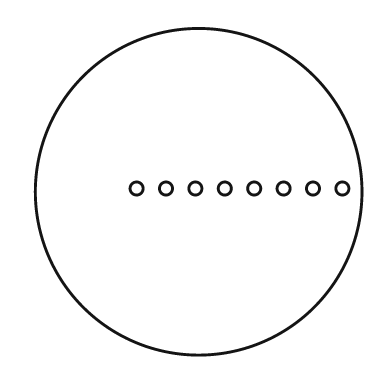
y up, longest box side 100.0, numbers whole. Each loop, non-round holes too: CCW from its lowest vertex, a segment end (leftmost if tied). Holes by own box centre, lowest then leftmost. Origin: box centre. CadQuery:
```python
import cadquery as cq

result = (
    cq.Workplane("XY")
    .moveTo(0.0, 0.0)
    .circle(50.0)
    .moveTo(-19.0, 1.0)
    .circle(2.0)
    .moveTo(-10.0, 1.0)
    .circle(2.0)
    .moveTo(-1.0, 1.0)
    .circle(2.0)
    .moveTo(8.0, 1.0)
    .circle(2.0)
    .moveTo(17.0, 1.0)
    .circle(2.0)
    .moveTo(26.0, 1.0)
    .circle(2.0)
    .moveTo(35.0, 1.0)
    .circle(2.0)
    .moveTo(44.0, 1.0)
    .circle(2.0)
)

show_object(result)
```